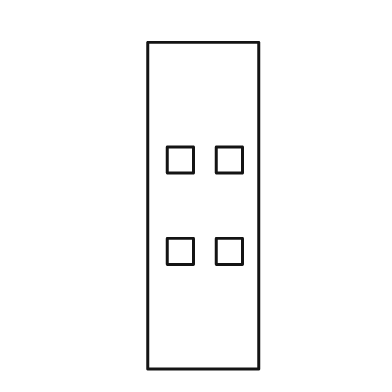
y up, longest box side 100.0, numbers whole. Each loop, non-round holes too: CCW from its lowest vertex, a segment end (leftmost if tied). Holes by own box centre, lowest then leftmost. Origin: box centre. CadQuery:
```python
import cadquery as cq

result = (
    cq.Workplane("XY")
    .moveTo(-17.0, -50.0)
    .lineTo(17.0, -50.0)
    .lineTo(17.0, 50.0)
    .lineTo(-17.0, 50.0)
    .close()
    .moveTo(-11.0, -18.0)
    .lineTo(-3.0, -18.0)
    .lineTo(-3.0, -10.0)
    .lineTo(-11.0, -10.0)
    .close()
    .moveTo(4.0, -18.0)
    .lineTo(12.0, -18.0)
    .lineTo(12.0, -10.0)
    .lineTo(4.0, -10.0)
    .close()
    .moveTo(-11.0, 10.0)
    .lineTo(-3.0, 10.0)
    .lineTo(-3.0, 18.0)
    .lineTo(-11.0, 18.0)
    .close()
    .moveTo(4.0, 10.0)
    .lineTo(12.0, 10.0)
    .lineTo(12.0, 18.0)
    .lineTo(4.0, 18.0)
    .close()
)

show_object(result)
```